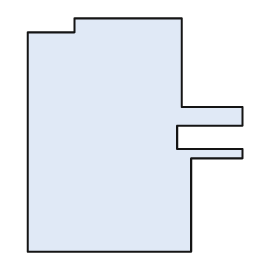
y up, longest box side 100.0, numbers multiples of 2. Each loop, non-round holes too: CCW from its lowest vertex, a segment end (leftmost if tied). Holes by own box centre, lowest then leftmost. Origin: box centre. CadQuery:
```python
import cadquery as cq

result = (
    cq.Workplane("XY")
    .moveTo(-46.0, -50.0)
    .lineTo(24.0, -50.0)
    .lineTo(24.0, -10.0)
    .lineTo(46.0, -10.0)
    .lineTo(46.0, -6.0)
    .lineTo(18.0, -6.0)
    .lineTo(18.0, 4.0)
    .lineTo(46.0, 4.0)
    .lineTo(46.0, 12.0)
    .lineTo(20.0, 12.0)
    .lineTo(20.0, 50.0)
    .lineTo(-26.0, 50.0)
    .lineTo(-26.0, 44.0)
    .lineTo(-46.0, 44.0)
    .close()
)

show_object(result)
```